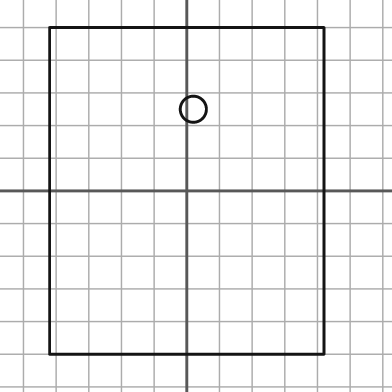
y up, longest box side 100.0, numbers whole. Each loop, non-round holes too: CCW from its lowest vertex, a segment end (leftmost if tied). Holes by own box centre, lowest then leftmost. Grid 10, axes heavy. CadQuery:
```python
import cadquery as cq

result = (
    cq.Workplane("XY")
    .moveTo(-42.0, -50.0)
    .lineTo(42.0, -50.0)
    .lineTo(42.0, 50.0)
    .lineTo(-42.0, 50.0)
    .close()
    .moveTo(2.0, 25.0)
    .circle(4.0)
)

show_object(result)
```